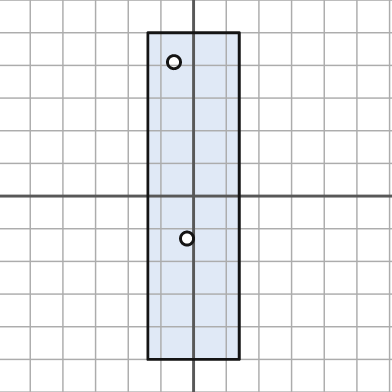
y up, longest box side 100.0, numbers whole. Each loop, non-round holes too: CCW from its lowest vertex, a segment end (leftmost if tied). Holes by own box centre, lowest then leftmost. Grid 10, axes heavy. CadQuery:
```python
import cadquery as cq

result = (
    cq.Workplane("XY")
    .moveTo(-14.0, -50.0)
    .lineTo(14.0, -50.0)
    .lineTo(14.0, 50.0)
    .lineTo(-14.0, 50.0)
    .close()
    .moveTo(-2.0, -13.0)
    .circle(2.0)
    .moveTo(-6.0, 41.0)
    .circle(2.0)
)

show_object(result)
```